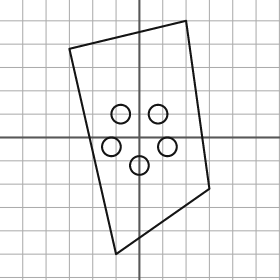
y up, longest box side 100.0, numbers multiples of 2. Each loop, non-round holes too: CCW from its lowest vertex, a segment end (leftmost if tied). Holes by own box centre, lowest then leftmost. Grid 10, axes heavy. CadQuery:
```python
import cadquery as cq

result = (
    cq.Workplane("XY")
    .moveTo(-10.0, -50.0)
    .lineTo(30.0, -22.0)
    .lineTo(20.0, 50.0)
    .lineTo(-30.0, 38.0)
    .close()
    .moveTo(0.0, -12.0)
    .circle(4.0)
    .moveTo(-12.0, -4.0)
    .circle(4.0)
    .moveTo(12.0, -4.0)
    .circle(4.0)
    .moveTo(-8.0, 10.0)
    .circle(4.0)
    .moveTo(8.0, 10.0)
    .circle(4.0)
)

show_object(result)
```